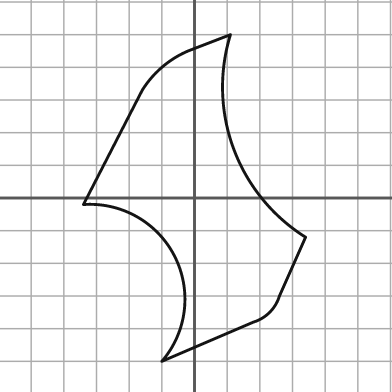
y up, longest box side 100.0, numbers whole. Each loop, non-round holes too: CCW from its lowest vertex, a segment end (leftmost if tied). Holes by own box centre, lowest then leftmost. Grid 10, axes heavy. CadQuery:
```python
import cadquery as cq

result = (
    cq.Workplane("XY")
    .moveTo(-10.0, -50.0)
    .lineTo(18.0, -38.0)
    .threePointArc((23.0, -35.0), (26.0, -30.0))
    .lineTo(34.0, -12.0)
    .threePointArc((12.0, 15.0), (11.0, 50.0))
    .lineTo(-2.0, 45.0)
    .threePointArc((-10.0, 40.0), (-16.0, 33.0))
    .lineTo(-34.0, -2.0)
    .threePointArc((-6.0, -18.0), (-10.0, -50.0))
    .close()
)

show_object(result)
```